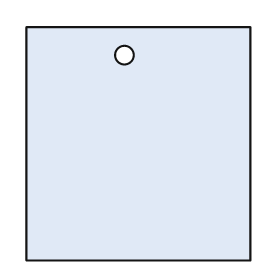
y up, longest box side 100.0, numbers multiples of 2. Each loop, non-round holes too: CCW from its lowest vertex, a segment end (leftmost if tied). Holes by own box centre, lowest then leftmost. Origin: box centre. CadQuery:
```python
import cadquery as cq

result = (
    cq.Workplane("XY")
    .moveTo(-48.0, -50.0)
    .lineTo(48.0, -50.0)
    .lineTo(48.0, 50.0)
    .lineTo(-48.0, 50.0)
    .close()
    .moveTo(-6.0, 38.0)
    .circle(4.0)
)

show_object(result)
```